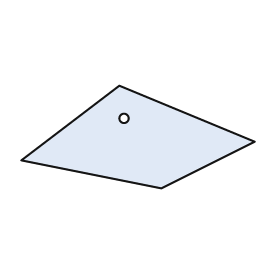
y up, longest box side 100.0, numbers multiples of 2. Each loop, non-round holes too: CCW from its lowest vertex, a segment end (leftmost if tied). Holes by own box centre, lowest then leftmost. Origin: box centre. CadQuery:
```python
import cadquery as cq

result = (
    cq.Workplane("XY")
    .moveTo(10.0, -22.0)
    .lineTo(50.0, -2.0)
    .lineTo(-8.0, 22.0)
    .lineTo(-50.0, -10.0)
    .close()
    .moveTo(-6.0, 8.0)
    .circle(2.0)
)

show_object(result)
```